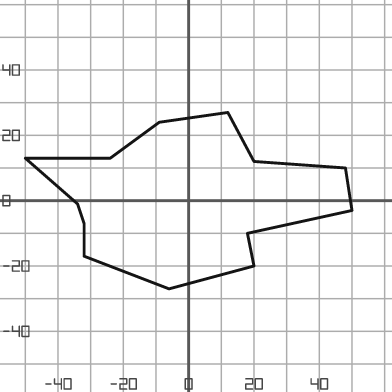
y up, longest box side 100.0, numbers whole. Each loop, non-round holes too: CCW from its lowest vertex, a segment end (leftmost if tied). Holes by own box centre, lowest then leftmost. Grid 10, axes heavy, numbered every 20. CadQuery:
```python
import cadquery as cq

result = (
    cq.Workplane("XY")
    .moveTo(-6.0, -27.0)
    .lineTo(20.0, -20.0)
    .lineTo(18.0, -10.0)
    .lineTo(50.0, -3.0)
    .lineTo(48.0, 10.0)
    .lineTo(20.0, 12.0)
    .lineTo(12.0, 27.0)
    .lineTo(-9.0, 24.0)
    .lineTo(-24.0, 13.0)
    .lineTo(-50.0, 13.0)
    .lineTo(-34.0, -1.0)
    .lineTo(-32.0, -7.0)
    .lineTo(-32.0, -17.0)
    .close()
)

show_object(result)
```